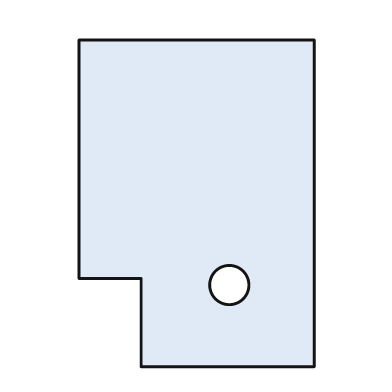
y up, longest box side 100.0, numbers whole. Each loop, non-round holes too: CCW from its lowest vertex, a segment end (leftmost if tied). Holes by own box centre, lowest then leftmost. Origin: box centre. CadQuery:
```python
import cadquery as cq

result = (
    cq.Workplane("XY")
    .moveTo(-17.0, -50.0)
    .lineTo(36.0, -50.0)
    .lineTo(36.0, 50.0)
    .lineTo(-36.0, 50.0)
    .lineTo(-36.0, -23.0)
    .lineTo(-17.0, -23.0)
    .close()
    .moveTo(10.0, -25.0)
    .circle(6.0)
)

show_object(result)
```